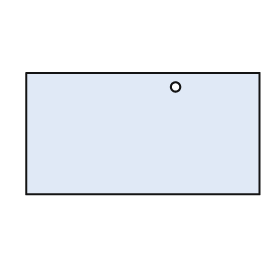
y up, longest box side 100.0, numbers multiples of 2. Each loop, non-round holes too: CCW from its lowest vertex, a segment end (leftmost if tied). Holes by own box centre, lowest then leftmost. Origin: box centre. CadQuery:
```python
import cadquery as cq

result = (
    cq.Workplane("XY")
    .moveTo(-50.0, -26.0)
    .lineTo(50.0, -26.0)
    .lineTo(50.0, 26.0)
    .lineTo(-50.0, 26.0)
    .close()
    .moveTo(14.0, 20.0)
    .circle(2.0)
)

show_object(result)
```